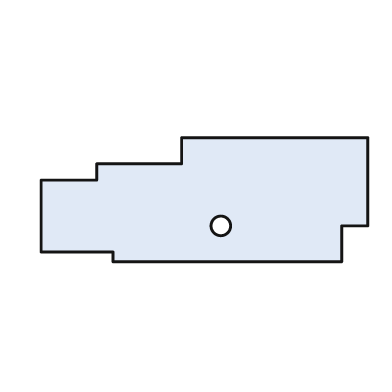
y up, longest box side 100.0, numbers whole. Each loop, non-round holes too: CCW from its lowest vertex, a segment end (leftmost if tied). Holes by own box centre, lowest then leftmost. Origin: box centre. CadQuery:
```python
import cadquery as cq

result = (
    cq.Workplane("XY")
    .moveTo(-28.0, -19.0)
    .lineTo(42.0, -19.0)
    .lineTo(42.0, -8.0)
    .lineTo(50.0, -8.0)
    .lineTo(50.0, 19.0)
    .lineTo(-7.0, 19.0)
    .lineTo(-7.0, 11.0)
    .lineTo(-33.0, 11.0)
    .lineTo(-33.0, 6.0)
    .lineTo(-50.0, 6.0)
    .lineTo(-50.0, -16.0)
    .lineTo(-28.0, -16.0)
    .close()
    .moveTo(5.0, -8.0)
    .circle(3.0)
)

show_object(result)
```